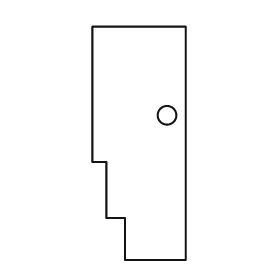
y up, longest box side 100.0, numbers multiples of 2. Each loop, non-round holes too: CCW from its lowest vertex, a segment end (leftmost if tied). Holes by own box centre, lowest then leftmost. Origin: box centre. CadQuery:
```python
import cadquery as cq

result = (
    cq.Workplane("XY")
    .moveTo(-6.0, -50.0)
    .lineTo(20.0, -50.0)
    .lineTo(20.0, 50.0)
    .lineTo(-20.0, 50.0)
    .lineTo(-20.0, -8.0)
    .lineTo(-14.0, -8.0)
    .lineTo(-14.0, -32.0)
    .lineTo(-6.0, -32.0)
    .close()
    .moveTo(12.0, 12.0)
    .circle(4.0)
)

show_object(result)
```